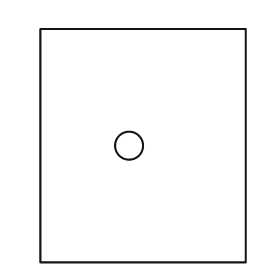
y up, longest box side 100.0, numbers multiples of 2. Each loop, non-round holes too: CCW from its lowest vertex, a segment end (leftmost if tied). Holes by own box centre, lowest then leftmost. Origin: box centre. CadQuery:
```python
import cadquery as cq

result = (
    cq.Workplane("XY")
    .moveTo(-44.0, -50.0)
    .lineTo(44.0, -50.0)
    .lineTo(44.0, 50.0)
    .lineTo(-44.0, 50.0)
    .close()
    .moveTo(-6.0, 0.0)
    .circle(6.0)
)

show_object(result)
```